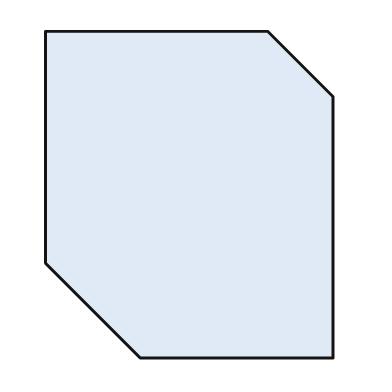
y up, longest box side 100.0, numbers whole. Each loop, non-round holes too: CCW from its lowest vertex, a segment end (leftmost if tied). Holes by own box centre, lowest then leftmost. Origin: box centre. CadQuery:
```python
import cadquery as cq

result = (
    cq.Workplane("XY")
    .moveTo(-15.0, -50.0)
    .lineTo(44.0, -50.0)
    .lineTo(44.0, 30.0)
    .lineTo(24.0, 50.0)
    .lineTo(-44.0, 50.0)
    .lineTo(-44.0, -21.0)
    .close()
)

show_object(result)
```